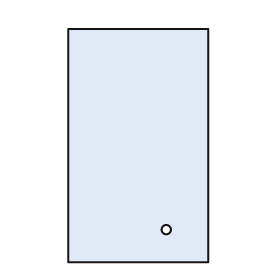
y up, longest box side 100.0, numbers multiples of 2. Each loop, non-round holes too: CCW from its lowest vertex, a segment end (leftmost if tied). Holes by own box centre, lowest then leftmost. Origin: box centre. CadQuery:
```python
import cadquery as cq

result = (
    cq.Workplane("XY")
    .moveTo(-30.0, -50.0)
    .lineTo(30.0, -50.0)
    .lineTo(30.0, 50.0)
    .lineTo(-30.0, 50.0)
    .close()
    .moveTo(12.0, -36.0)
    .circle(2.0)
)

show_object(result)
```